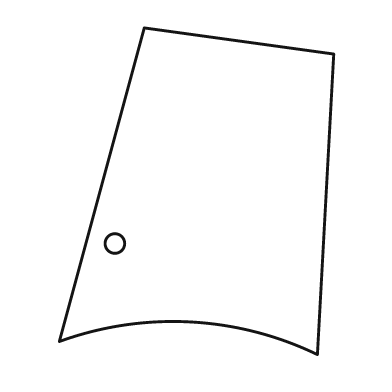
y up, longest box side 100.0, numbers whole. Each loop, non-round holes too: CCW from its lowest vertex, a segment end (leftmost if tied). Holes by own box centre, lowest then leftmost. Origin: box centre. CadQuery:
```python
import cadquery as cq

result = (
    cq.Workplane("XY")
    .moveTo(37.0, -50.0)
    .lineTo(42.0, 42.0)
    .lineTo(-16.0, 50.0)
    .lineTo(-42.0, -46.0)
    .threePointArc((-2.0, -40.0), (37.0, -50.0))
    .close()
    .moveTo(-25.0, -16.0)
    .circle(3.0)
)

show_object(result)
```